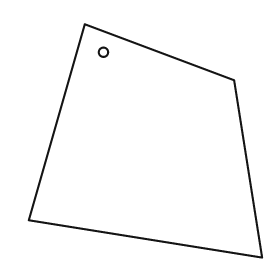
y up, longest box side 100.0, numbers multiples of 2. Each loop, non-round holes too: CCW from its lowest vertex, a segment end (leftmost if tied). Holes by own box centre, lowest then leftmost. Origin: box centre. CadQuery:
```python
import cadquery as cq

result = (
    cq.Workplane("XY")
    .moveTo(50.0, -50.0)
    .lineTo(38.0, 26.0)
    .lineTo(-26.0, 50.0)
    .lineTo(-50.0, -34.0)
    .close()
    .moveTo(-18.0, 38.0)
    .circle(2.0)
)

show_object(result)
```